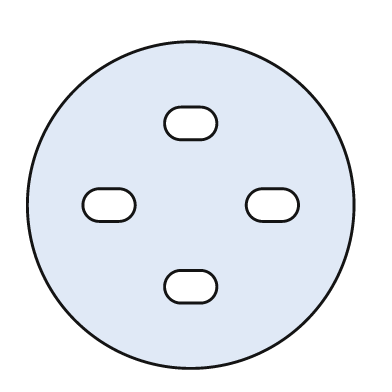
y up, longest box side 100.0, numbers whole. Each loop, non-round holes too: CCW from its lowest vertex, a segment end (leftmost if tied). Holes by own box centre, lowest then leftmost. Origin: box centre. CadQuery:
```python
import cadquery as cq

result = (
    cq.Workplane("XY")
    .moveTo(0.0, 0.0)
    .circle(50.0)
    .moveTo(-3.0, -30.0)
    .lineTo(3.0, -30.0)
    .threePointArc((8.0, -25.0), (3.0, -20.0))
    .lineTo(-3.0, -20.0)
    .threePointArc((-8.0, -25.0), (-3.0, -30.0))
    .close()
    .moveTo(-28.0, -5.0)
    .lineTo(-22.0, -5.0)
    .threePointArc((-17.0, 0.0), (-22.0, 5.0))
    .lineTo(-28.0, 5.0)
    .threePointArc((-33.0, 0.0), (-28.0, -5.0))
    .close()
    .moveTo(22.0, -5.0)
    .lineTo(28.0, -5.0)
    .threePointArc((33.0, 0.0), (28.0, 5.0))
    .lineTo(22.0, 5.0)
    .threePointArc((17.0, 0.0), (22.0, -5.0))
    .close()
    .moveTo(-3.0, 20.0)
    .lineTo(3.0, 20.0)
    .threePointArc((8.0, 25.0), (3.0, 30.0))
    .lineTo(-3.0, 30.0)
    .threePointArc((-8.0, 25.0), (-3.0, 20.0))
    .close()
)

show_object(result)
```